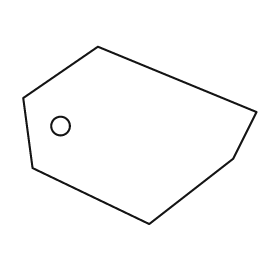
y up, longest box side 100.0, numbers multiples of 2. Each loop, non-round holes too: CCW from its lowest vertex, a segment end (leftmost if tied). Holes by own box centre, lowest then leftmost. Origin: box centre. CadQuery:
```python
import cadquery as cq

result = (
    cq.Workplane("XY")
    .moveTo(4.0, -38.0)
    .lineTo(40.0, -10.0)
    .lineTo(50.0, 10.0)
    .lineTo(-18.0, 38.0)
    .lineTo(-50.0, 16.0)
    .lineTo(-46.0, -14.0)
    .close()
    .moveTo(-34.0, 4.0)
    .circle(4.0)
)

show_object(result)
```